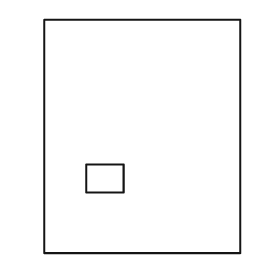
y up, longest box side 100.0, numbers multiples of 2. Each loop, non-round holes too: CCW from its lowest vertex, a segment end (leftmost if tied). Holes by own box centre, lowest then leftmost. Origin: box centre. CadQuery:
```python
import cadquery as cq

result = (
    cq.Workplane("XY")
    .moveTo(-42.0, -50.0)
    .lineTo(42.0, -50.0)
    .lineTo(42.0, 50.0)
    .lineTo(-42.0, 50.0)
    .close()
    .moveTo(-24.0, -24.0)
    .lineTo(-8.0, -24.0)
    .lineTo(-8.0, -12.0)
    .lineTo(-24.0, -12.0)
    .close()
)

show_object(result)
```